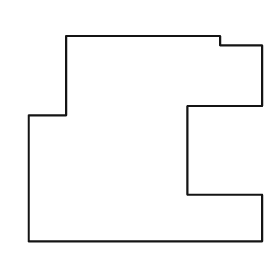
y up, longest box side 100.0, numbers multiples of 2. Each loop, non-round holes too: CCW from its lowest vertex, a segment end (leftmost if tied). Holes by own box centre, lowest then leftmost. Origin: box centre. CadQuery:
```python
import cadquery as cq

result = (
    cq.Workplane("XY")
    .moveTo(-50.0, -44.0)
    .lineTo(50.0, -44.0)
    .lineTo(50.0, -24.0)
    .lineTo(18.0, -24.0)
    .lineTo(18.0, 14.0)
    .lineTo(50.0, 14.0)
    .lineTo(50.0, 40.0)
    .lineTo(32.0, 40.0)
    .lineTo(32.0, 44.0)
    .lineTo(-34.0, 44.0)
    .lineTo(-34.0, 10.0)
    .lineTo(-50.0, 10.0)
    .close()
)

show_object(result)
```